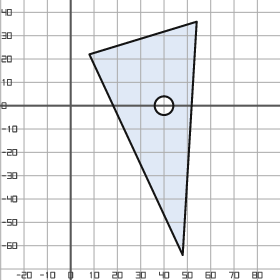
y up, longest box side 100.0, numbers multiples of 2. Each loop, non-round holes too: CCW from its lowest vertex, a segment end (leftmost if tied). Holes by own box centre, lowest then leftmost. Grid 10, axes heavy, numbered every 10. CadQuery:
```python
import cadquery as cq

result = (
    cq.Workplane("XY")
    .moveTo(48.0, -64.0)
    .lineTo(54.0, 36.0)
    .lineTo(8.0, 22.0)
    .close()
    .moveTo(40.0, 0.0)
    .circle(4.0)
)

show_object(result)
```